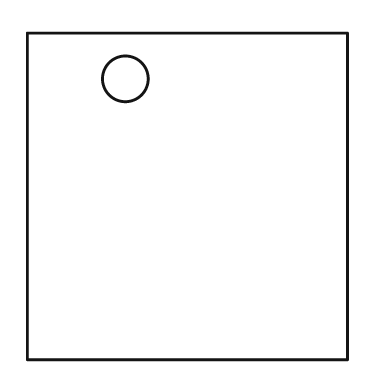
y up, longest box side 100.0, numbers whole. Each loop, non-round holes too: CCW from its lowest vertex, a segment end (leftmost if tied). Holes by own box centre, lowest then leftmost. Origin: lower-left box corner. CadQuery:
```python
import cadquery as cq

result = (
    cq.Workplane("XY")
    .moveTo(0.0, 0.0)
    .lineTo(98.0, 0.0)
    .lineTo(98.0, 100.0)
    .lineTo(0.0, 100.0)
    .close()
    .moveTo(30.0, 86.0)
    .circle(7.0)
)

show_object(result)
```